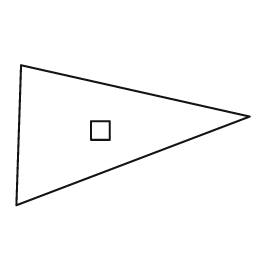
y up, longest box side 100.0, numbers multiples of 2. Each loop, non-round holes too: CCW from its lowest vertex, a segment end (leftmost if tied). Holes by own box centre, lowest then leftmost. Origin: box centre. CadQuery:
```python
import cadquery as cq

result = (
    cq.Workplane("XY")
    .moveTo(-50.0, -30.0)
    .lineTo(50.0, 8.0)
    .lineTo(-48.0, 30.0)
    .close()
    .moveTo(-18.0, -2.0)
    .lineTo(-10.0, -2.0)
    .lineTo(-10.0, 6.0)
    .lineTo(-18.0, 6.0)
    .close()
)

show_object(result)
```